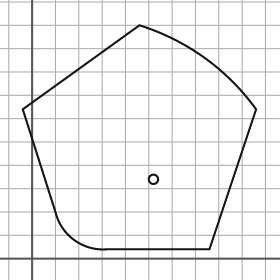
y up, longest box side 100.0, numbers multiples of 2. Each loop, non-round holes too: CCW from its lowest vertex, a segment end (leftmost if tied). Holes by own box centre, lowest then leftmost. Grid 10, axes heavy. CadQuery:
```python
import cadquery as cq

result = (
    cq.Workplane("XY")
    .moveTo(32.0, 4.0)
    .lineTo(76.0, 4.0)
    .lineTo(96.0, 64.0)
    .threePointArc((74.0, 86.0), (46.0, 100.0))
    .lineTo(-4.0, 64.0)
    .lineTo(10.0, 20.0)
    .threePointArc((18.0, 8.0), (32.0, 4.0))
    .close()
    .moveTo(52.0, 34.0)
    .circle(2.0)
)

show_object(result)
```